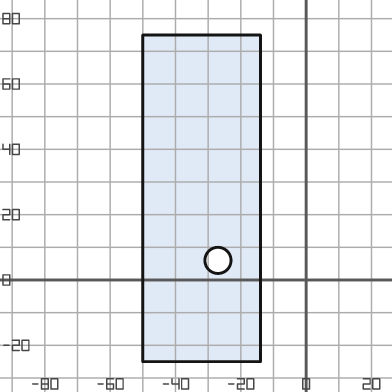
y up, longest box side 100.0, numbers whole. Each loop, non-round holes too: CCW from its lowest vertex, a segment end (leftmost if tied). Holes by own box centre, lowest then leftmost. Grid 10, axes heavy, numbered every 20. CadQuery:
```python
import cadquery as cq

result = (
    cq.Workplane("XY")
    .moveTo(-50.0, -25.0)
    .lineTo(-14.0, -25.0)
    .lineTo(-14.0, 75.0)
    .lineTo(-50.0, 75.0)
    .close()
    .moveTo(-27.0, 6.0)
    .circle(4.0)
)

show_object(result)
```